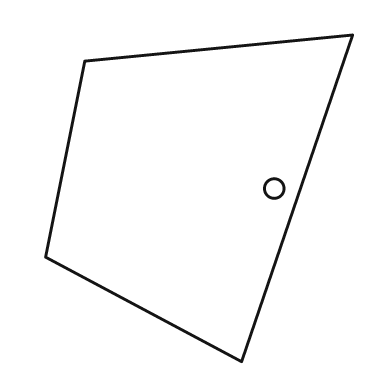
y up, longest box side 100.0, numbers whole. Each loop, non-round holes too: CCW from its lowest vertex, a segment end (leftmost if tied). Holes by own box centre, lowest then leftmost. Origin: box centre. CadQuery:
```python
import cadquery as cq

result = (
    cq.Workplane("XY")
    .moveTo(13.0, -50.0)
    .lineTo(47.0, 50.0)
    .lineTo(-35.0, 42.0)
    .lineTo(-47.0, -18.0)
    .close()
    .moveTo(23.0, 3.0)
    .circle(3.0)
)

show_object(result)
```